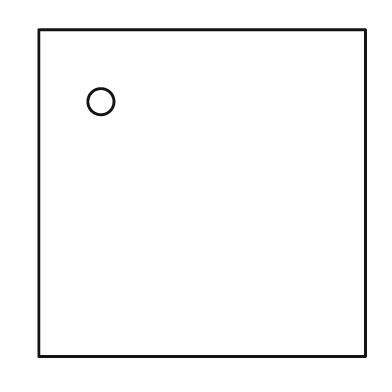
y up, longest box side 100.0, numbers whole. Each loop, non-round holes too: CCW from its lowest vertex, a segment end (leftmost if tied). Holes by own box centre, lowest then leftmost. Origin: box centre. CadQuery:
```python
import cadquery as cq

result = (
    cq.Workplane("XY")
    .moveTo(-50.0, -50.0)
    .lineTo(50.0, -50.0)
    .lineTo(50.0, 50.0)
    .lineTo(-50.0, 50.0)
    .close()
    .moveTo(-31.0, 28.0)
    .circle(4.0)
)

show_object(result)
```